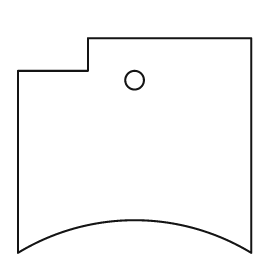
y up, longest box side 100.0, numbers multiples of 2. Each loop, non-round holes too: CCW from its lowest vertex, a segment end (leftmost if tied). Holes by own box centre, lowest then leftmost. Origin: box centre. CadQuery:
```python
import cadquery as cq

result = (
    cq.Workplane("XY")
    .moveTo(-50.0, -46.0)
    .threePointArc((0.0, -32.0), (50.0, -46.0))
    .lineTo(50.0, 46.0)
    .lineTo(-20.0, 46.0)
    .lineTo(-20.0, 32.0)
    .lineTo(-50.0, 32.0)
    .close()
    .moveTo(0.0, 28.0)
    .circle(4.0)
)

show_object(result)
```